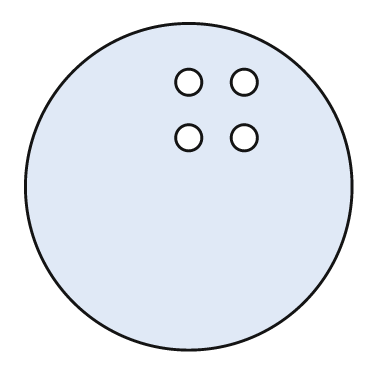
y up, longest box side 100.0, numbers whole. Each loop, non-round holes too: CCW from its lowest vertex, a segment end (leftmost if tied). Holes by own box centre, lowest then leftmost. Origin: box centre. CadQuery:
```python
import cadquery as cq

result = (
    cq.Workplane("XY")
    .moveTo(0.0, 0.0)
    .circle(50.0)
    .moveTo(0.0, 15.0)
    .circle(4.0)
    .moveTo(17.0, 15.0)
    .circle(4.0)
    .moveTo(0.0, 32.0)
    .circle(4.0)
    .moveTo(17.0, 32.0)
    .circle(4.0)
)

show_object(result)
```